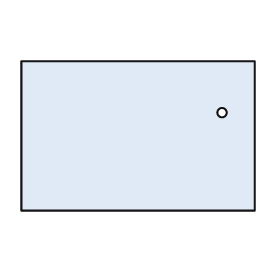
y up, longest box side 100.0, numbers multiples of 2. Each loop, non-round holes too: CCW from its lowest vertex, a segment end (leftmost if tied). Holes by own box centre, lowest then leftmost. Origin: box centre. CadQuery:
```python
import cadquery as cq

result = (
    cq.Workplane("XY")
    .moveTo(-50.0, -32.0)
    .lineTo(50.0, -32.0)
    .lineTo(50.0, 32.0)
    .lineTo(-50.0, 32.0)
    .close()
    .moveTo(36.0, 10.0)
    .circle(2.0)
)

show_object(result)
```